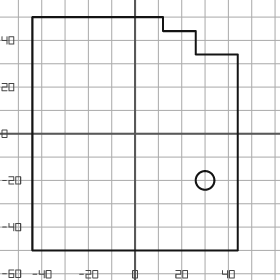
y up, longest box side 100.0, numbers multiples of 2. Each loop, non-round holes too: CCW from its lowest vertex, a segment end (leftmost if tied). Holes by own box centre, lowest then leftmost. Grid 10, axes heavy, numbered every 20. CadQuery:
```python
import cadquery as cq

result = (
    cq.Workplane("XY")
    .moveTo(-44.0, -50.0)
    .lineTo(44.0, -50.0)
    .lineTo(44.0, 34.0)
    .lineTo(26.0, 34.0)
    .lineTo(26.0, 44.0)
    .lineTo(12.0, 44.0)
    .lineTo(12.0, 50.0)
    .lineTo(-44.0, 50.0)
    .close()
    .moveTo(30.0, -20.0)
    .circle(4.0)
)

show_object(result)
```